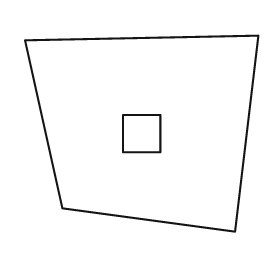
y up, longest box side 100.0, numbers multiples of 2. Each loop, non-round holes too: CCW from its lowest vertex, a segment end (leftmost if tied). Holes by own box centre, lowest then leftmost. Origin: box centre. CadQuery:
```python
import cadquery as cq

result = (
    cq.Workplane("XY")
    .moveTo(40.0, -42.0)
    .lineTo(50.0, 42.0)
    .lineTo(-50.0, 40.0)
    .lineTo(-34.0, -32.0)
    .close()
    .moveTo(-8.0, -8.0)
    .lineTo(8.0, -8.0)
    .lineTo(8.0, 8.0)
    .lineTo(-8.0, 8.0)
    .close()
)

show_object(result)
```